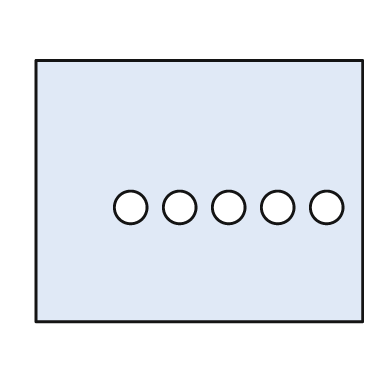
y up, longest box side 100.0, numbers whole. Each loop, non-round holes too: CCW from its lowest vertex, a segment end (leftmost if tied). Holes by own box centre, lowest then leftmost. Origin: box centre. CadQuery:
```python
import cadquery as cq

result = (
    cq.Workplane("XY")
    .moveTo(-50.0, -40.0)
    .lineTo(50.0, -40.0)
    .lineTo(50.0, 40.0)
    .lineTo(-50.0, 40.0)
    .close()
    .moveTo(-21.0, -5.0)
    .circle(5.0)
    .moveTo(-6.0, -5.0)
    .circle(5.0)
    .moveTo(9.0, -5.0)
    .circle(5.0)
    .moveTo(24.0, -5.0)
    .circle(5.0)
    .moveTo(39.0, -5.0)
    .circle(5.0)
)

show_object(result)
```